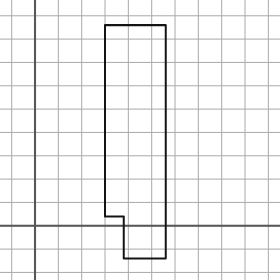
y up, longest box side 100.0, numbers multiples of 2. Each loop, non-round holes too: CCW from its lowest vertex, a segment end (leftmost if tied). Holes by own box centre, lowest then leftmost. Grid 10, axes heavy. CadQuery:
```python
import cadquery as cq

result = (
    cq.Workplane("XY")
    .moveTo(38.0, -14.0)
    .lineTo(56.0, -14.0)
    .lineTo(56.0, 86.0)
    .lineTo(30.0, 86.0)
    .lineTo(30.0, 4.0)
    .lineTo(38.0, 4.0)
    .close()
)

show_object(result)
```